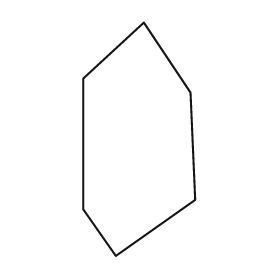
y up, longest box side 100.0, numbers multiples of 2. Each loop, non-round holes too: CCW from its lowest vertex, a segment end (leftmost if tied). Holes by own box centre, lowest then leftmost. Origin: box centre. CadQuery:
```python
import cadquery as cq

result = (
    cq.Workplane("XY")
    .moveTo(-10.0, -50.0)
    .lineTo(24.0, -26.0)
    .lineTo(22.0, 20.0)
    .lineTo(2.0, 50.0)
    .lineTo(-24.0, 26.0)
    .lineTo(-24.0, -30.0)
    .close()
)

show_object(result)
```